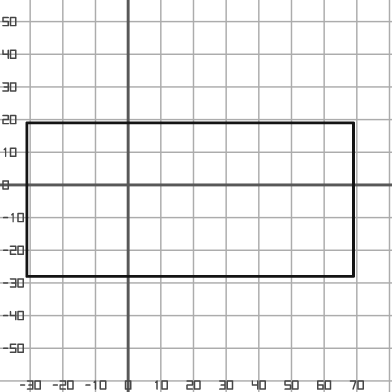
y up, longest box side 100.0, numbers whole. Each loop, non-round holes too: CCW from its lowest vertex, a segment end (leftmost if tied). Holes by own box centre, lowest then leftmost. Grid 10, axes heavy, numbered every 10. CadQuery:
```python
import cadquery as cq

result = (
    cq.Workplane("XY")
    .moveTo(-31.0, -28.0)
    .lineTo(69.0, -28.0)
    .lineTo(69.0, 19.0)
    .lineTo(-31.0, 19.0)
    .close()
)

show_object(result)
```